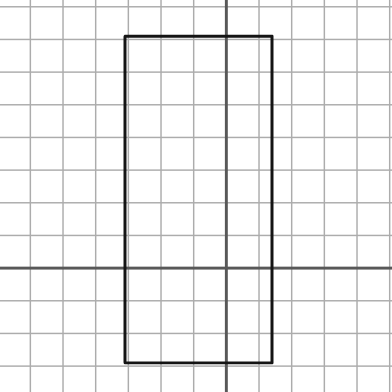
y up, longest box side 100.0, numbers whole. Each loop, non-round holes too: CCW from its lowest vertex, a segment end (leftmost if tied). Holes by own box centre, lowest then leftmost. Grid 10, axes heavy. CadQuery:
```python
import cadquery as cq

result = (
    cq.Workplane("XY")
    .moveTo(-31.0, -29.0)
    .lineTo(14.0, -29.0)
    .lineTo(14.0, 71.0)
    .lineTo(-31.0, 71.0)
    .close()
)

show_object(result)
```